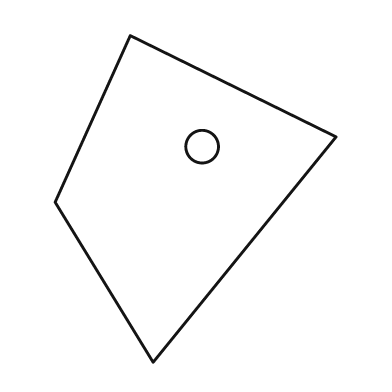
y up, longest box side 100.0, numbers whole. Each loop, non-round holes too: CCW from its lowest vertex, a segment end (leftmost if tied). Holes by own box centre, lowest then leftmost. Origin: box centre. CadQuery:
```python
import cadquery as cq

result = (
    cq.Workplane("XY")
    .moveTo(-13.0, -50.0)
    .lineTo(43.0, 19.0)
    .lineTo(-20.0, 50.0)
    .lineTo(-43.0, -1.0)
    .close()
    .moveTo(2.0, 16.0)
    .circle(5.0)
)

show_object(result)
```